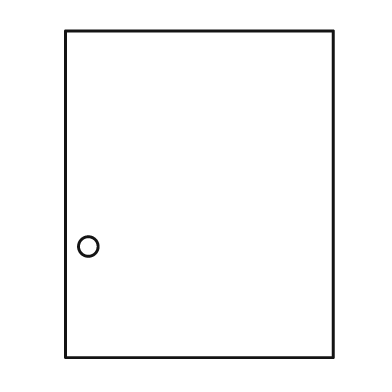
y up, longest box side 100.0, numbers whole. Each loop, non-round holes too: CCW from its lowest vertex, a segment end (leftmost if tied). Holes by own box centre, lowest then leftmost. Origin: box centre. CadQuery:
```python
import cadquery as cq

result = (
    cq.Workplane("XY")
    .moveTo(-41.0, -50.0)
    .lineTo(41.0, -50.0)
    .lineTo(41.0, 50.0)
    .lineTo(-41.0, 50.0)
    .close()
    .moveTo(-34.0, -16.0)
    .circle(3.0)
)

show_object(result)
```